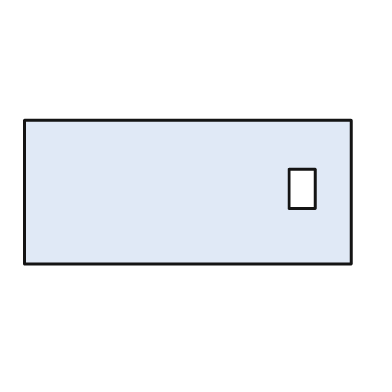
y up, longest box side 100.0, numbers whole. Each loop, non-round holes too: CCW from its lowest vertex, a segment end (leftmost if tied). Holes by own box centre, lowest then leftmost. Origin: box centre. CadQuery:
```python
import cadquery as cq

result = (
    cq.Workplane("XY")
    .moveTo(-50.0, -22.0)
    .lineTo(50.0, -22.0)
    .lineTo(50.0, 22.0)
    .lineTo(-50.0, 22.0)
    .close()
    .moveTo(31.0, -5.0)
    .lineTo(39.0, -5.0)
    .lineTo(39.0, 7.0)
    .lineTo(31.0, 7.0)
    .close()
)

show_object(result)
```